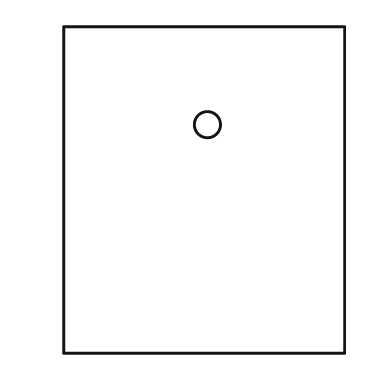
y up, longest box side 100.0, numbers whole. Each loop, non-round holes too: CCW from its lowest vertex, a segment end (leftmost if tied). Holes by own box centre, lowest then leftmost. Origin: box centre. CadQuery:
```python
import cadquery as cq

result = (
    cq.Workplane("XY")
    .moveTo(-43.0, -50.0)
    .lineTo(43.0, -50.0)
    .lineTo(43.0, 50.0)
    .lineTo(-43.0, 50.0)
    .close()
    .moveTo(1.0, 20.0)
    .circle(4.0)
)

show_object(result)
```